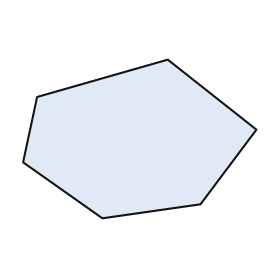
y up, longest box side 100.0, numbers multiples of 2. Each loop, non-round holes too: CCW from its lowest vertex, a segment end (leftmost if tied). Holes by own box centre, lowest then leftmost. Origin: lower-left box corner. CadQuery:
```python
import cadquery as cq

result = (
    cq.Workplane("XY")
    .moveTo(34.0, 0.0)
    .lineTo(76.0, 6.0)
    .lineTo(100.0, 38.0)
    .lineTo(62.0, 68.0)
    .lineTo(6.0, 52.0)
    .lineTo(0.0, 24.0)
    .close()
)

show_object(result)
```